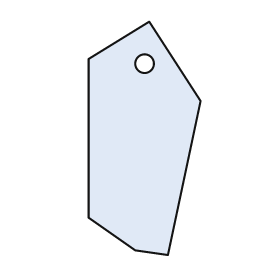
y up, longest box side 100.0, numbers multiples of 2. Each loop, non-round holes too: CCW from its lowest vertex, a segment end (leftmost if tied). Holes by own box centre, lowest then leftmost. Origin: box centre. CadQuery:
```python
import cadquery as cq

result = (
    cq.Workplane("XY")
    .moveTo(10.0, -50.0)
    .lineTo(24.0, 16.0)
    .lineTo(2.0, 50.0)
    .lineTo(-24.0, 34.0)
    .lineTo(-24.0, -34.0)
    .lineTo(-4.0, -48.0)
    .close()
    .moveTo(0.0, 32.0)
    .circle(4.0)
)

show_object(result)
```